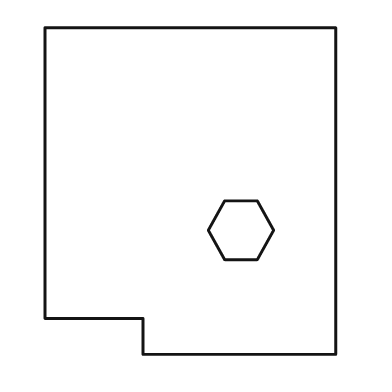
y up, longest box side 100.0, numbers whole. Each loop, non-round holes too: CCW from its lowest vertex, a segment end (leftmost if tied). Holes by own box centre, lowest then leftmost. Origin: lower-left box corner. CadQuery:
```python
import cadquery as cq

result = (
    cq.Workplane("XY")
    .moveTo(30.0, 0.0)
    .lineTo(89.0, 0.0)
    .lineTo(89.0, 100.0)
    .lineTo(0.0, 100.0)
    .lineTo(0.0, 11.0)
    .lineTo(30.0, 11.0)
    .close()
    .moveTo(55.0, 29.0)
    .lineTo(65.0, 29.0)
    .lineTo(70.0, 38.0)
    .lineTo(65.0, 47.0)
    .lineTo(55.0, 47.0)
    .lineTo(50.0, 38.0)
    .close()
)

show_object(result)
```